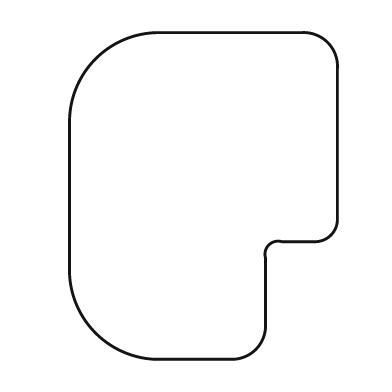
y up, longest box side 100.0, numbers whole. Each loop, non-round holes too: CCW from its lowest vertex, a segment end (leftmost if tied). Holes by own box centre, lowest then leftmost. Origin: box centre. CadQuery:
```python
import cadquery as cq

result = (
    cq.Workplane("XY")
    .moveTo(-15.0, -50.0)
    .lineTo(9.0, -50.0)
    .threePointArc((16.0, -47.0), (19.0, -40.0))
    .lineTo(19.0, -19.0)
    .threePointArc((20.0, -15.0), (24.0, -14.0))
    .lineTo(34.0, -14.0)
    .threePointArc((39.0, -12.0), (41.0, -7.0))
    .lineTo(41.0, 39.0)
    .threePointArc((38.0, 47.0), (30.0, 50.0))
    .lineTo(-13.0, 50.0)
    .threePointArc((-33.0, 42.0), (-41.0, 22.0))
    .lineTo(-41.0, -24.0)
    .threePointArc((-33.0, -42.0), (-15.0, -50.0))
    .close()
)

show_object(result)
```